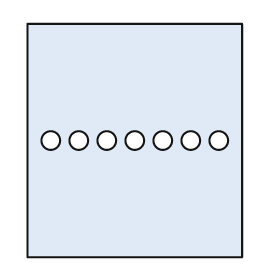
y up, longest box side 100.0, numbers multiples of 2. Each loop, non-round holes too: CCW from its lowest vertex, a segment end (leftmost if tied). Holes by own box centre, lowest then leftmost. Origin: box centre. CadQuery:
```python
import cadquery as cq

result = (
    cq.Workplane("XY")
    .moveTo(-46.0, -50.0)
    .lineTo(46.0, -50.0)
    .lineTo(46.0, 50.0)
    .lineTo(-46.0, 50.0)
    .close()
    .moveTo(-36.0, 0.0)
    .circle(4.0)
    .moveTo(-24.0, 0.0)
    .circle(4.0)
    .moveTo(-12.0, 0.0)
    .circle(4.0)
    .moveTo(0.0, 0.0)
    .circle(4.0)
    .moveTo(12.0, 0.0)
    .circle(4.0)
    .moveTo(24.0, 0.0)
    .circle(4.0)
    .moveTo(36.0, 0.0)
    .circle(4.0)
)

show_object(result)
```